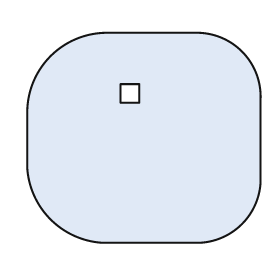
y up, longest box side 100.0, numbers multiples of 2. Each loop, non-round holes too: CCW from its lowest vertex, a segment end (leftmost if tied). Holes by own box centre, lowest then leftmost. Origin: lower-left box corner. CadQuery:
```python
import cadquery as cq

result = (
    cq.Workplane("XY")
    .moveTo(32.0, 0.0)
    .lineTo(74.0, 0.0)
    .threePointArc((92.0, 8.0), (100.0, 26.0))
    .lineTo(100.0, 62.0)
    .threePointArc((92.0, 82.0), (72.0, 90.0))
    .lineTo(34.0, 90.0)
    .threePointArc((10.0, 80.0), (0.0, 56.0))
    .lineTo(0.0, 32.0)
    .threePointArc((10.0, 10.0), (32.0, 0.0))
    .close()
    .moveTo(40.0, 60.0)
    .lineTo(48.0, 60.0)
    .lineTo(48.0, 68.0)
    .lineTo(40.0, 68.0)
    .close()
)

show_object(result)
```